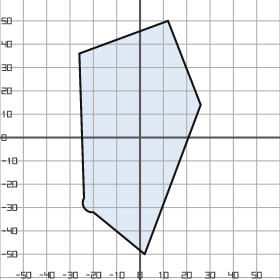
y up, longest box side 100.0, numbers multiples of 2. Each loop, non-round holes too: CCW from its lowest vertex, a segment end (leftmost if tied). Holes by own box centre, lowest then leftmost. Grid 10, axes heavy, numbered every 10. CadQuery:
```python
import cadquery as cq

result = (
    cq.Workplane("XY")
    .moveTo(2.0, -50.0)
    .lineTo(26.0, 14.0)
    .lineTo(12.0, 50.0)
    .lineTo(-26.0, 36.0)
    .lineTo(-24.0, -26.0)
    .threePointArc((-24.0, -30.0), (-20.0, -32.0))
    .close()
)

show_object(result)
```